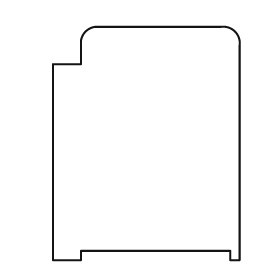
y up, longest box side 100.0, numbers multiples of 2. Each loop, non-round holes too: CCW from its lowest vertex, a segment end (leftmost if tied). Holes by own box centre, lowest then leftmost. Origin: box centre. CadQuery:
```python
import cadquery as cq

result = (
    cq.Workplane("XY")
    .moveTo(-40.0, -50.0)
    .lineTo(-28.0, -50.0)
    .lineTo(-28.0, -46.0)
    .lineTo(36.0, -46.0)
    .lineTo(36.0, -50.0)
    .lineTo(40.0, -50.0)
    .lineTo(40.0, 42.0)
    .threePointArc((38.0, 48.0), (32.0, 50.0))
    .lineTo(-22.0, 50.0)
    .threePointArc((-26.0, 48.0), (-28.0, 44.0))
    .lineTo(-28.0, 34.0)
    .lineTo(-40.0, 34.0)
    .close()
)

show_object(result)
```